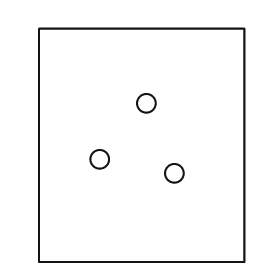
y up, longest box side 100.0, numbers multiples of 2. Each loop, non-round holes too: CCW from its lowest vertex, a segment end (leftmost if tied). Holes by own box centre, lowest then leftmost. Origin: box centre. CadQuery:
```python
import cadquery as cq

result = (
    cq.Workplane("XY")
    .moveTo(-44.0, -50.0)
    .lineTo(44.0, -50.0)
    .lineTo(44.0, 50.0)
    .lineTo(-44.0, 50.0)
    .close()
    .moveTo(14.0, -12.0)
    .circle(4.0)
    .moveTo(-18.0, -6.0)
    .circle(4.0)
    .moveTo(2.0, 18.0)
    .circle(4.0)
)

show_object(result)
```